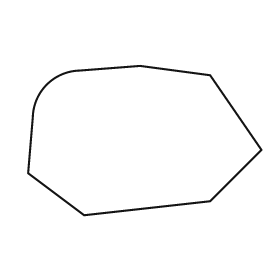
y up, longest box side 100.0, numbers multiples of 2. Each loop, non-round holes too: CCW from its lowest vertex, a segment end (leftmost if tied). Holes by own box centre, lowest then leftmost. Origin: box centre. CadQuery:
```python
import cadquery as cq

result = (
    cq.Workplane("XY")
    .moveTo(-26.0, -32.0)
    .lineTo(28.0, -26.0)
    .lineTo(50.0, -4.0)
    .lineTo(28.0, 28.0)
    .lineTo(-2.0, 32.0)
    .lineTo(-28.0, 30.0)
    .threePointArc((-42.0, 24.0), (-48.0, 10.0))
    .lineTo(-50.0, -14.0)
    .close()
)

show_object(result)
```